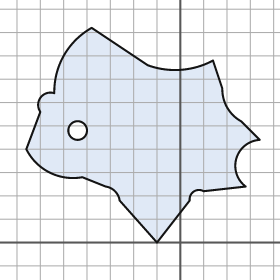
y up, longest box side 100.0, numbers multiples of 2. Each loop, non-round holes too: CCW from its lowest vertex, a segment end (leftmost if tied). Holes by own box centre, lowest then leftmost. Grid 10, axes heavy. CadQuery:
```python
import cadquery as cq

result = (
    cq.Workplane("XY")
    .moveTo(-10.0, 0.0)
    .lineTo(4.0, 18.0)
    .threePointArc((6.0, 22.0), (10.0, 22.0))
    .lineTo(28.0, 24.0)
    .threePointArc((24.0, 36.0), (34.0, 44.0))
    .lineTo(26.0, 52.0)
    .threePointArc((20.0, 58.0), (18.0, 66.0))
    .lineTo(14.0, 78.0)
    .threePointArc((0.0, 74.0), (-14.0, 76.0))
    .lineTo(-38.0, 92.0)
    .threePointArc((-50.0, 80.0), (-54.0, 64.0))
    .threePointArc((-60.0, 62.0), (-60.0, 56.0))
    .lineTo(-66.0, 40.0)
    .threePointArc((-56.0, 30.0), (-42.0, 28.0))
    .lineTo(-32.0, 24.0)
    .threePointArc((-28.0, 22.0), (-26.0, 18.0))
    .close()
    .moveTo(-44.0, 48.0)
    .circle(4.0)
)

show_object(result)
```